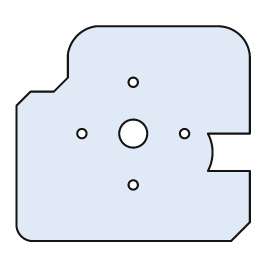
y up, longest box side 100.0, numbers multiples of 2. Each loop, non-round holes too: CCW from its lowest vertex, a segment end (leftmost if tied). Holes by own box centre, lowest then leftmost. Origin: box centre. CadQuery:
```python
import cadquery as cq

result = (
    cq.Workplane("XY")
    .moveTo(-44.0, -46.0)
    .lineTo(42.0, -46.0)
    .lineTo(50.0, -38.0)
    .lineTo(50.0, -16.0)
    .lineTo(32.0, -16.0)
    .threePointArc((34.0, -8.0), (32.0, 0.0))
    .lineTo(50.0, 0.0)
    .lineTo(50.0, 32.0)
    .threePointArc((46.0, 42.0), (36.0, 46.0))
    .lineTo(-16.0, 46.0)
    .threePointArc((-24.0, 42.0), (-28.0, 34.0))
    .lineTo(-28.0, 24.0)
    .lineTo(-34.0, 18.0)
    .lineTo(-44.0, 18.0)
    .lineTo(-50.0, 12.0)
    .lineTo(-50.0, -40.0)
    .threePointArc((-48.0, -44.0), (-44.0, -46.0))
    .close()
    .moveTo(0.0, -22.0)
    .circle(2.0)
    .moveTo(-22.0, 0.0)
    .circle(2.0)
    .moveTo(0.0, 0.0)
    .circle(6.0)
    .moveTo(22.0, 0.0)
    .circle(2.0)
    .moveTo(0.0, 22.0)
    .circle(2.0)
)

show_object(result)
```